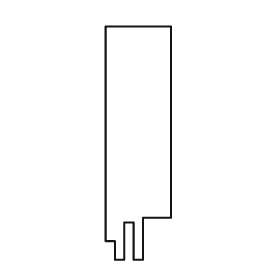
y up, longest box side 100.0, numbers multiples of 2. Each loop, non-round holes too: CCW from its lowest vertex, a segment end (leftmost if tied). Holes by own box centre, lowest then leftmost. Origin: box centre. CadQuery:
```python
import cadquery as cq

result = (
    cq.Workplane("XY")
    .moveTo(-10.0, -50.0)
    .lineTo(-6.0, -50.0)
    .lineTo(-6.0, -34.0)
    .lineTo(-2.0, -34.0)
    .lineTo(-2.0, -50.0)
    .lineTo(2.0, -50.0)
    .lineTo(2.0, -32.0)
    .lineTo(14.0, -32.0)
    .lineTo(14.0, 50.0)
    .lineTo(-14.0, 50.0)
    .lineTo(-14.0, -42.0)
    .lineTo(-10.0, -42.0)
    .close()
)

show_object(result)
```